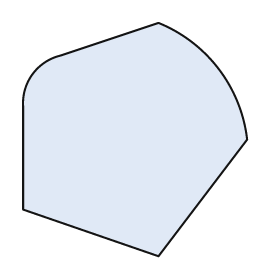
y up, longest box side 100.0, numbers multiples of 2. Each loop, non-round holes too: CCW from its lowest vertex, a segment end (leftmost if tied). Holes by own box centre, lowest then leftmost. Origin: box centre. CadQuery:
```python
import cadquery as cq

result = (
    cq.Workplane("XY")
    .moveTo(10.0, -50.0)
    .lineTo(48.0, 0.0)
    .threePointArc((36.0, 30.0), (10.0, 50.0))
    .lineTo(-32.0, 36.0)
    .threePointArc((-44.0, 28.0), (-48.0, 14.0))
    .lineTo(-48.0, -30.0)
    .close()
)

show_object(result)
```